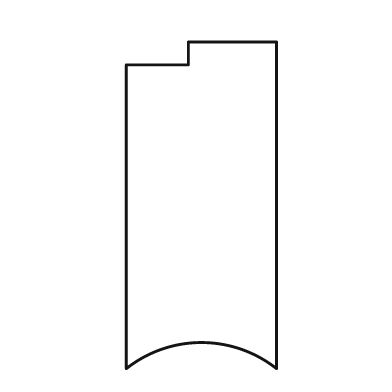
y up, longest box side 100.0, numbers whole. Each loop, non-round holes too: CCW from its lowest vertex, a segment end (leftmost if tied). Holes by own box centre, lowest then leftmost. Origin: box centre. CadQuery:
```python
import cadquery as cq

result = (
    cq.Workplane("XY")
    .moveTo(-23.0, -50.0)
    .threePointArc((0.0, -42.0), (23.0, -50.0))
    .lineTo(23.0, 50.0)
    .lineTo(-4.0, 50.0)
    .lineTo(-4.0, 43.0)
    .lineTo(-23.0, 43.0)
    .close()
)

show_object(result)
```